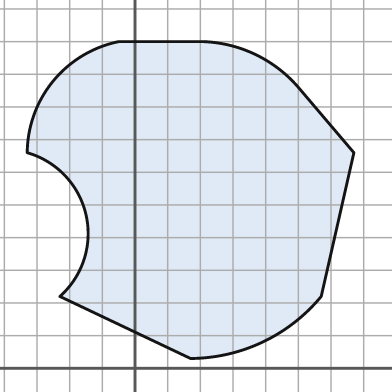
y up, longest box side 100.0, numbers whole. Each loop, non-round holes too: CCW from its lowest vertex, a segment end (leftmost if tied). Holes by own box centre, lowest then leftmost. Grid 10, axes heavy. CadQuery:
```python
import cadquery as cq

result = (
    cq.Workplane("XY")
    .moveTo(17.0, 3.0)
    .threePointArc((39.0, 8.0), (57.0, 22.0))
    .lineTo(67.0, 66.0)
    .lineTo(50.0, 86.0)
    .threePointArc((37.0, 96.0), (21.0, 100.0))
    .lineTo(-5.0, 100.0)
    .threePointArc((-25.0, 88.0), (-33.0, 66.0))
    .threePointArc((-15.0, 47.0), (-23.0, 22.0))
    .close()
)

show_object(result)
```